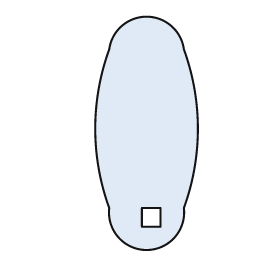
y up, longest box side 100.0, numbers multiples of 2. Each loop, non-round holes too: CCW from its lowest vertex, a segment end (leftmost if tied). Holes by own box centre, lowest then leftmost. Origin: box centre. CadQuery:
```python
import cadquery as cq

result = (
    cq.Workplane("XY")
    .moveTo(-16.0, -32.0)
    .threePointArc((0.0, -50.0), (16.0, -32.0))
    .threePointArc((22.0, 2.0), (16.0, 36.0))
    .threePointArc((0.0, 50.0), (-16.0, 36.0))
    .threePointArc((-22.0, 2.0), (-16.0, -32.0))
    .close()
    .moveTo(-2.0, -40.0)
    .lineTo(6.0, -40.0)
    .lineTo(6.0, -32.0)
    .lineTo(-2.0, -32.0)
    .close()
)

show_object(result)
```